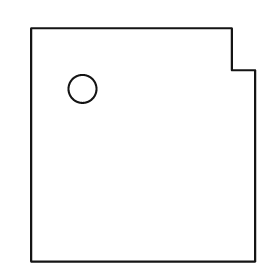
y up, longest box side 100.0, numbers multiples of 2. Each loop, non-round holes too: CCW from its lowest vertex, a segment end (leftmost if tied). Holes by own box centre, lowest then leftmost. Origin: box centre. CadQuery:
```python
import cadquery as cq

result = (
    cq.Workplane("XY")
    .moveTo(-48.0, -50.0)
    .lineTo(48.0, -50.0)
    .lineTo(48.0, 32.0)
    .lineTo(38.0, 32.0)
    .lineTo(38.0, 50.0)
    .lineTo(-48.0, 50.0)
    .close()
    .moveTo(-26.0, 24.0)
    .circle(6.0)
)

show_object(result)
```